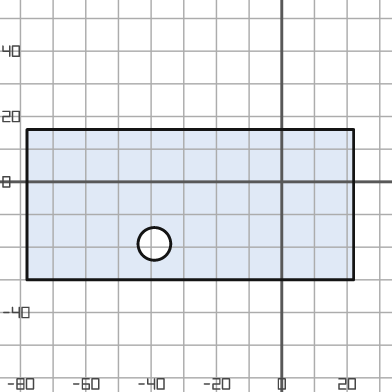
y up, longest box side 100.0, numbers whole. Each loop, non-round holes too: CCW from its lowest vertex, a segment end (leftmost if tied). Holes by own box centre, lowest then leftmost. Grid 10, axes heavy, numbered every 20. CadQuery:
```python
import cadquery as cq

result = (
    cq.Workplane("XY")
    .moveTo(-78.0, -30.0)
    .lineTo(22.0, -30.0)
    .lineTo(22.0, 16.0)
    .lineTo(-78.0, 16.0)
    .close()
    .moveTo(-39.0, -19.0)
    .circle(5.0)
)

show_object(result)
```